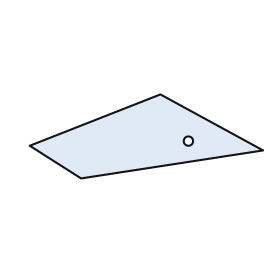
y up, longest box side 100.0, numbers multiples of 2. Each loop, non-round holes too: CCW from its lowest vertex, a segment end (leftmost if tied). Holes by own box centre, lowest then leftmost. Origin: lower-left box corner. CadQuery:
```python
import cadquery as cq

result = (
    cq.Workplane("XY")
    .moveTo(22.0, 0.0)
    .lineTo(100.0, 12.0)
    .lineTo(56.0, 36.0)
    .lineTo(0.0, 14.0)
    .close()
    .moveTo(68.0, 16.0)
    .circle(2.0)
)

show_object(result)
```